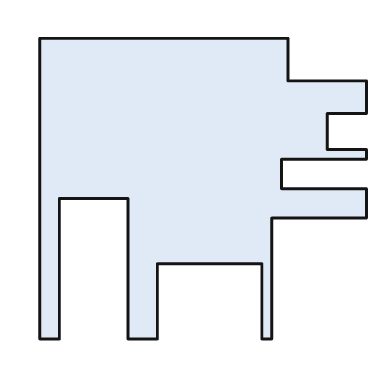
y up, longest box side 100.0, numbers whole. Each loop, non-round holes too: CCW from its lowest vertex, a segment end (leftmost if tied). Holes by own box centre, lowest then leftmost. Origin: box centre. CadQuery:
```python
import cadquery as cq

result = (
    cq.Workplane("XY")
    .moveTo(-50.0, -46.0)
    .lineTo(-44.0, -46.0)
    .lineTo(-44.0, -3.0)
    .lineTo(-23.0, -3.0)
    .lineTo(-23.0, -46.0)
    .lineTo(-14.0, -46.0)
    .lineTo(-14.0, -23.0)
    .lineTo(18.0, -23.0)
    .lineTo(18.0, -46.0)
    .lineTo(21.0, -46.0)
    .lineTo(21.0, -9.0)
    .lineTo(50.0, -9.0)
    .lineTo(50.0, 0.0)
    .lineTo(24.0, 0.0)
    .lineTo(24.0, 9.0)
    .lineTo(50.0, 9.0)
    .lineTo(50.0, 12.0)
    .lineTo(38.0, 12.0)
    .lineTo(38.0, 23.0)
    .lineTo(50.0, 23.0)
    .lineTo(50.0, 33.0)
    .lineTo(26.0, 33.0)
    .lineTo(26.0, 46.0)
    .lineTo(-50.0, 46.0)
    .close()
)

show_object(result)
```